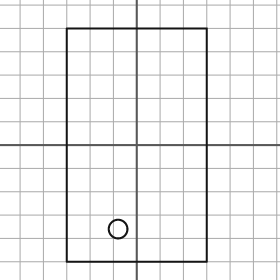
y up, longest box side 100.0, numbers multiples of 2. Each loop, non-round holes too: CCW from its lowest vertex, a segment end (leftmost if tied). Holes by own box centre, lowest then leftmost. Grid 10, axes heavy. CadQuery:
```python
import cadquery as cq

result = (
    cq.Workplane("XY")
    .moveTo(-30.0, -50.0)
    .lineTo(30.0, -50.0)
    .lineTo(30.0, 50.0)
    .lineTo(-30.0, 50.0)
    .close()
    .moveTo(-8.0, -36.0)
    .circle(4.0)
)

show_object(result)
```